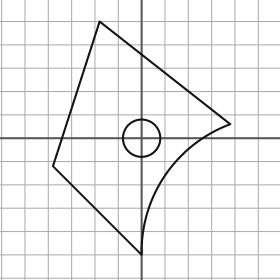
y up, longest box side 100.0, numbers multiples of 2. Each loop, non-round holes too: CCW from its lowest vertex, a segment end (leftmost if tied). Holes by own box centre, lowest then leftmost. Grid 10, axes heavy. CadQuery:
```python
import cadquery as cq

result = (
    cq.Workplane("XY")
    .moveTo(0.0, -50.0)
    .threePointArc((10.0, -16.0), (38.0, 6.0))
    .lineTo(-18.0, 50.0)
    .lineTo(-38.0, -12.0)
    .close()
    .moveTo(0.0, 0.0)
    .circle(8.0)
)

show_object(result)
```